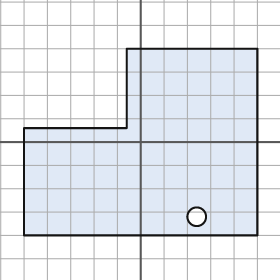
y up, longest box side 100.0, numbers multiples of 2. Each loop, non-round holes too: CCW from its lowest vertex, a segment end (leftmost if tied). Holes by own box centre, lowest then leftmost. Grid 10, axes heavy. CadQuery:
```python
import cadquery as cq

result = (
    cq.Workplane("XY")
    .moveTo(-50.0, -40.0)
    .lineTo(50.0, -40.0)
    .lineTo(50.0, 40.0)
    .lineTo(-6.0, 40.0)
    .lineTo(-6.0, 6.0)
    .lineTo(-50.0, 6.0)
    .close()
    .moveTo(24.0, -32.0)
    .circle(4.0)
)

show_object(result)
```